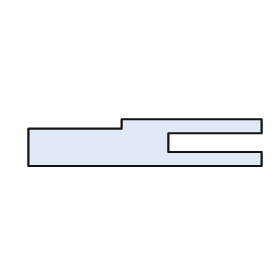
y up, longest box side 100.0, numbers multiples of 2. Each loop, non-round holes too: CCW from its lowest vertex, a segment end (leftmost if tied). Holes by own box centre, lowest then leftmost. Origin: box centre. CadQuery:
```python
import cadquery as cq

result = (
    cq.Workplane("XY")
    .moveTo(-50.0, -10.0)
    .lineTo(50.0, -10.0)
    .lineTo(50.0, -4.0)
    .lineTo(10.0, -4.0)
    .lineTo(10.0, 4.0)
    .lineTo(50.0, 4.0)
    .lineTo(50.0, 10.0)
    .lineTo(-10.0, 10.0)
    .lineTo(-10.0, 6.0)
    .lineTo(-50.0, 6.0)
    .close()
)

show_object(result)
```